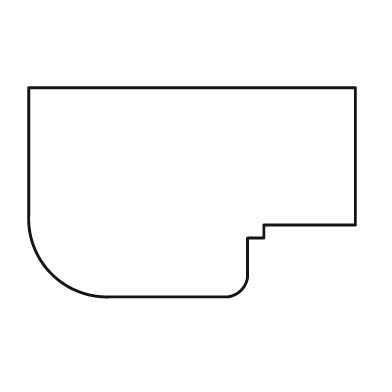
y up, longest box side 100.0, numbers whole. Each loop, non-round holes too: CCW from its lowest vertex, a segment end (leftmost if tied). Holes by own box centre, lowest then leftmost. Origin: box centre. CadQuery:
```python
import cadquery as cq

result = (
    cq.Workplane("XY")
    .moveTo(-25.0, -32.0)
    .lineTo(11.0, -32.0)
    .threePointArc((15.0, -30.0), (17.0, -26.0))
    .lineTo(17.0, -14.0)
    .lineTo(22.0, -14.0)
    .lineTo(22.0, -10.0)
    .lineTo(50.0, -10.0)
    .lineTo(50.0, 32.0)
    .lineTo(-50.0, 32.0)
    .lineTo(-50.0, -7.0)
    .threePointArc((-43.0, -25.0), (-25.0, -32.0))
    .close()
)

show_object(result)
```